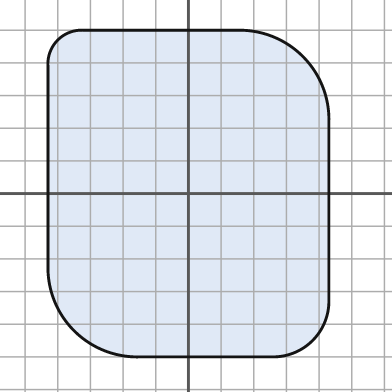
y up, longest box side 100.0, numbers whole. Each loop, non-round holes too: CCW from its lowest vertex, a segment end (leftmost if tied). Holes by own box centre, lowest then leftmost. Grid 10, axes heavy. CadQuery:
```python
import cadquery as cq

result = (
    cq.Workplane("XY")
    .moveTo(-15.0, -50.0)
    .lineTo(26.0, -50.0)
    .threePointArc((38.0, -45.0), (43.0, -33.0))
    .lineTo(43.0, 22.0)
    .threePointArc((35.0, 42.0), (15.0, 50.0))
    .lineTo(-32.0, 50.0)
    .threePointArc((-40.0, 47.0), (-43.0, 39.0))
    .lineTo(-43.0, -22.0)
    .threePointArc((-35.0, -42.0), (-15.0, -50.0))
    .close()
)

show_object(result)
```